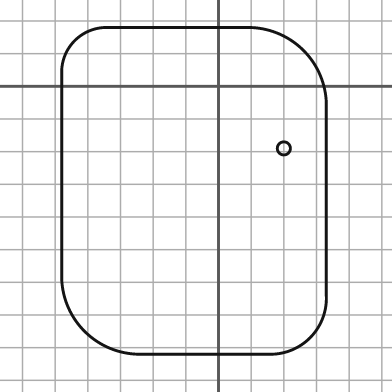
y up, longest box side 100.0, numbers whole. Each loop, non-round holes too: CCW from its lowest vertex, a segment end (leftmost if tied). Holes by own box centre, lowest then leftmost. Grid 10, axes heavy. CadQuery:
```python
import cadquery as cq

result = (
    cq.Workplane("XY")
    .moveTo(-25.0, -82.0)
    .lineTo(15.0, -82.0)
    .threePointArc((28.0, -77.0), (33.0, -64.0))
    .lineTo(33.0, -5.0)
    .threePointArc((26.0, 11.0), (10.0, 18.0))
    .lineTo(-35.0, 18.0)
    .threePointArc((-44.0, 14.0), (-48.0, 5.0))
    .lineTo(-48.0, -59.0)
    .threePointArc((-41.0, -75.0), (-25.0, -82.0))
    .close()
    .moveTo(20.0, -19.0)
    .circle(2.0)
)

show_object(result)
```